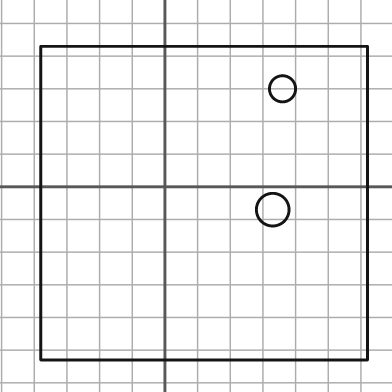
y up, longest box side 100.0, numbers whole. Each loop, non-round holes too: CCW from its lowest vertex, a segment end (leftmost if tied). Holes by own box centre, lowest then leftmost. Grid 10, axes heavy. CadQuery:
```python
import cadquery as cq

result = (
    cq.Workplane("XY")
    .moveTo(-38.0, -53.0)
    .lineTo(62.0, -53.0)
    .lineTo(62.0, 43.0)
    .lineTo(-38.0, 43.0)
    .close()
    .moveTo(33.0, -7.0)
    .circle(5.0)
    .moveTo(36.0, 30.0)
    .circle(4.0)
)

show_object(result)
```